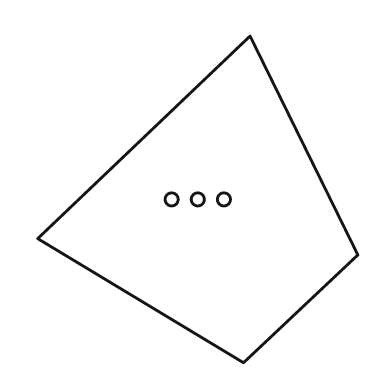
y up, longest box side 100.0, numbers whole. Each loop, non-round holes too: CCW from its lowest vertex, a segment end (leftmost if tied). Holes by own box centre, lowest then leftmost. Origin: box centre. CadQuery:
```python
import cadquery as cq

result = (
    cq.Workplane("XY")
    .moveTo(14.0, -50.0)
    .lineTo(49.0, -17.0)
    .lineTo(16.0, 50.0)
    .lineTo(-49.0, -12.0)
    .close()
    .moveTo(-8.0, 0.0)
    .circle(2.0)
    .moveTo(0.0, 0.0)
    .circle(2.0)
    .moveTo(8.0, 0.0)
    .circle(2.0)
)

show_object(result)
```